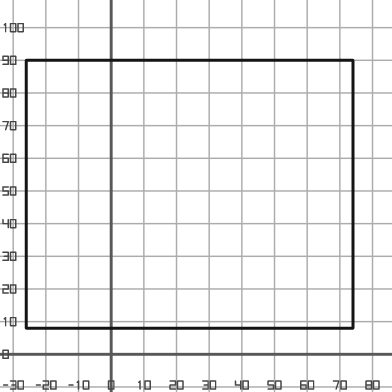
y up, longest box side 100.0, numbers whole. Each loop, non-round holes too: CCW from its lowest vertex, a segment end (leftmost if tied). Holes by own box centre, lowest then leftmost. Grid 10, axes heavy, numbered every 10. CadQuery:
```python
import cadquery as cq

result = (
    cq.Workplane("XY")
    .moveTo(-26.0, 8.0)
    .lineTo(74.0, 8.0)
    .lineTo(74.0, 90.0)
    .lineTo(-26.0, 90.0)
    .close()
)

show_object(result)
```